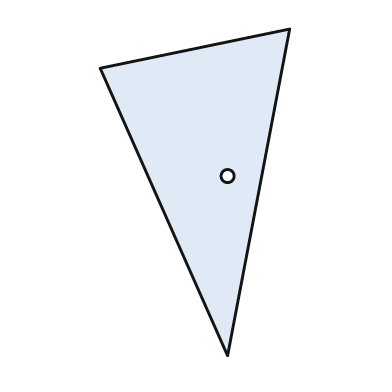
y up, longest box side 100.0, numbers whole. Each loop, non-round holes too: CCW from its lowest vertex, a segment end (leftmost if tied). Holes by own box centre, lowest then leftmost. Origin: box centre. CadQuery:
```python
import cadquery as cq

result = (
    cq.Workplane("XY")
    .moveTo(10.0, -50.0)
    .lineTo(29.0, 50.0)
    .lineTo(-29.0, 38.0)
    .close()
    .moveTo(10.0, 5.0)
    .circle(2.0)
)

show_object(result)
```